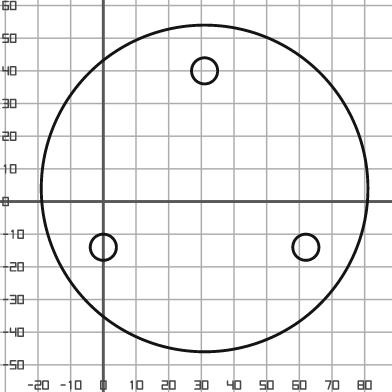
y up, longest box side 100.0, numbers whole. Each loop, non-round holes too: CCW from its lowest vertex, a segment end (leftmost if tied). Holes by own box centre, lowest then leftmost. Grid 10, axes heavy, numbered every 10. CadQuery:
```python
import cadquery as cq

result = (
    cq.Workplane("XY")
    .moveTo(31.0, 4.0)
    .circle(50.0)
    .moveTo(0.0, -14.0)
    .circle(4.0)
    .moveTo(62.0, -14.0)
    .circle(4.0)
    .moveTo(31.0, 40.0)
    .circle(4.0)
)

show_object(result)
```